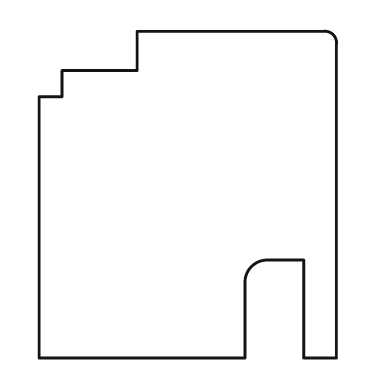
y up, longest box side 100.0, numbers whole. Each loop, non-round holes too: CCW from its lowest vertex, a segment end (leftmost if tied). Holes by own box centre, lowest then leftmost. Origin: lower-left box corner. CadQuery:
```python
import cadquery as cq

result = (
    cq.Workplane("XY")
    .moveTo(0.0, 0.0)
    .lineTo(63.0, 0.0)
    .lineTo(63.0, 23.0)
    .threePointArc((65.0, 28.0), (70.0, 30.0))
    .lineTo(81.0, 30.0)
    .lineTo(81.0, 0.0)
    .lineTo(91.0, 0.0)
    .lineTo(91.0, 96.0)
    .threePointArc((90.0, 99.0), (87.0, 100.0))
    .lineTo(30.0, 100.0)
    .lineTo(30.0, 88.0)
    .lineTo(7.0, 88.0)
    .lineTo(7.0, 80.0)
    .lineTo(0.0, 80.0)
    .close()
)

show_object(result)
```